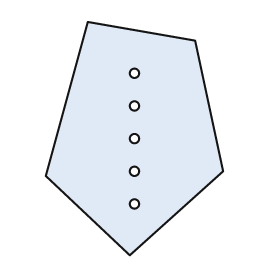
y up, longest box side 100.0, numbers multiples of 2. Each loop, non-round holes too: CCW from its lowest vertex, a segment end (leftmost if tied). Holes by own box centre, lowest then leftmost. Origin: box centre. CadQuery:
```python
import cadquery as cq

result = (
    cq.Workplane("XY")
    .moveTo(-2.0, -50.0)
    .lineTo(38.0, -14.0)
    .lineTo(26.0, 42.0)
    .lineTo(-20.0, 50.0)
    .lineTo(-38.0, -16.0)
    .close()
    .moveTo(0.0, -28.0)
    .circle(2.0)
    .moveTo(0.0, -14.0)
    .circle(2.0)
    .moveTo(0.0, 0.0)
    .circle(2.0)
    .moveTo(0.0, 14.0)
    .circle(2.0)
    .moveTo(0.0, 28.0)
    .circle(2.0)
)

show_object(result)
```